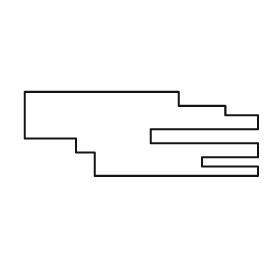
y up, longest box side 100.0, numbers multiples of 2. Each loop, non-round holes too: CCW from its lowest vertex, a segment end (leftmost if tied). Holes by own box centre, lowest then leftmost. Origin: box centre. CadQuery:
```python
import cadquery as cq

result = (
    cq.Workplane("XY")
    .moveTo(-20.0, -18.0)
    .lineTo(50.0, -18.0)
    .lineTo(50.0, -14.0)
    .lineTo(26.0, -14.0)
    .lineTo(26.0, -10.0)
    .lineTo(50.0, -10.0)
    .lineTo(50.0, -4.0)
    .lineTo(4.0, -4.0)
    .lineTo(4.0, 2.0)
    .lineTo(50.0, 2.0)
    .lineTo(50.0, 8.0)
    .lineTo(36.0, 8.0)
    .lineTo(36.0, 12.0)
    .lineTo(16.0, 12.0)
    .lineTo(16.0, 18.0)
    .lineTo(-50.0, 18.0)
    .lineTo(-50.0, -2.0)
    .lineTo(-28.0, -2.0)
    .lineTo(-28.0, -8.0)
    .lineTo(-20.0, -8.0)
    .close()
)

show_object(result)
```